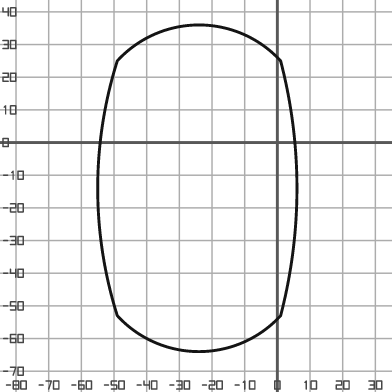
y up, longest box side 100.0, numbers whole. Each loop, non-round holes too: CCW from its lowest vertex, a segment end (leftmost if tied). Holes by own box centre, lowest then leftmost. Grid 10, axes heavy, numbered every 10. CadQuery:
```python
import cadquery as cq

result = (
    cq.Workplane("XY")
    .moveTo(-49.0, -53.0)
    .threePointArc((-24.0, -64.0), (1.0, -53.0))
    .threePointArc((6.0, -14.0), (1.0, 25.0))
    .threePointArc((-24.0, 36.0), (-49.0, 25.0))
    .threePointArc((-55.0, -14.0), (-49.0, -53.0))
    .close()
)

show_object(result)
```